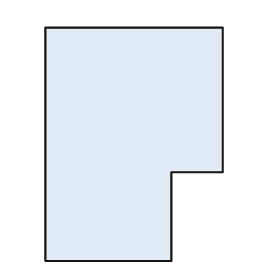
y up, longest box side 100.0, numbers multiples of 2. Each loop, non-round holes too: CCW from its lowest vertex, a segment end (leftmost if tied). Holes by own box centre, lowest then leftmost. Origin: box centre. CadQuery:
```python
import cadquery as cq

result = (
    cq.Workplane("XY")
    .moveTo(-38.0, -50.0)
    .lineTo(16.0, -50.0)
    .lineTo(16.0, -12.0)
    .lineTo(38.0, -12.0)
    .lineTo(38.0, 50.0)
    .lineTo(-38.0, 50.0)
    .close()
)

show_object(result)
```